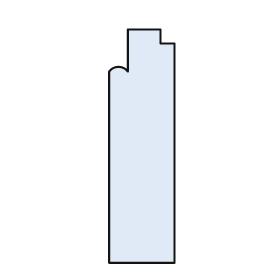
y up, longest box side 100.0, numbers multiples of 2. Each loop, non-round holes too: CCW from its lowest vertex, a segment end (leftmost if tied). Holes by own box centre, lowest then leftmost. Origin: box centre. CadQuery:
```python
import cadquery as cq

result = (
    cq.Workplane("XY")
    .moveTo(-14.0, -50.0)
    .lineTo(14.0, -50.0)
    .lineTo(14.0, 44.0)
    .lineTo(8.0, 44.0)
    .lineTo(8.0, 50.0)
    .lineTo(-6.0, 50.0)
    .lineTo(-6.0, 32.0)
    .threePointArc((-10.0, 34.0), (-14.0, 32.0))
    .close()
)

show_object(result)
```